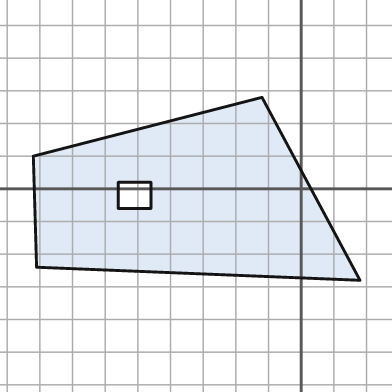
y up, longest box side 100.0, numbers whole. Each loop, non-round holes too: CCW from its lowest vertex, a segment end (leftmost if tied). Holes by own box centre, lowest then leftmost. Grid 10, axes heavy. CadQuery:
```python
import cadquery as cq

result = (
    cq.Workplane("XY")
    .moveTo(18.0, -28.0)
    .lineTo(-12.0, 28.0)
    .lineTo(-82.0, 10.0)
    .lineTo(-81.0, -24.0)
    .close()
    .moveTo(-56.0, -6.0)
    .lineTo(-46.0, -6.0)
    .lineTo(-46.0, 2.0)
    .lineTo(-56.0, 2.0)
    .close()
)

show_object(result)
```